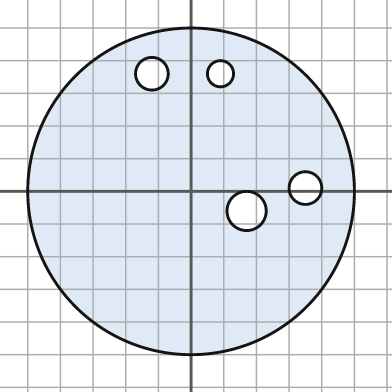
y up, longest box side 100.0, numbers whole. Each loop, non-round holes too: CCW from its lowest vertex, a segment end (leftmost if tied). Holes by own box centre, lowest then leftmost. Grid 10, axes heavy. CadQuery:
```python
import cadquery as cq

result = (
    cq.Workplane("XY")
    .moveTo(0.0, 0.0)
    .circle(50.0)
    .moveTo(17.0, -6.0)
    .circle(6.0)
    .moveTo(35.0, 1.0)
    .circle(5.0)
    .moveTo(-12.0, 36.0)
    .circle(5.0)
    .moveTo(9.0, 36.0)
    .circle(4.0)
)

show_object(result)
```